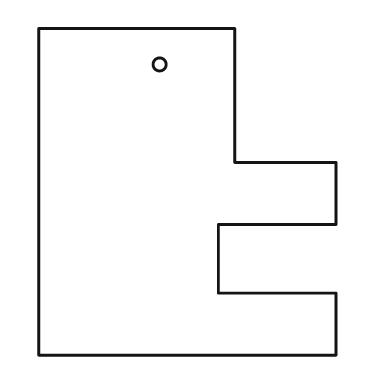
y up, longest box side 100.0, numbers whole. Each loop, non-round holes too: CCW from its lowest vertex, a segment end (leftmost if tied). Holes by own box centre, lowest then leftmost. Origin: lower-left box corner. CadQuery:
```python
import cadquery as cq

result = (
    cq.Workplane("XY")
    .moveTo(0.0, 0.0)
    .lineTo(91.0, 0.0)
    .lineTo(91.0, 19.0)
    .lineTo(55.0, 19.0)
    .lineTo(55.0, 40.0)
    .lineTo(91.0, 40.0)
    .lineTo(91.0, 59.0)
    .lineTo(60.0, 59.0)
    .lineTo(60.0, 100.0)
    .lineTo(0.0, 100.0)
    .close()
    .moveTo(37.0, 89.0)
    .circle(2.0)
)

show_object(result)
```